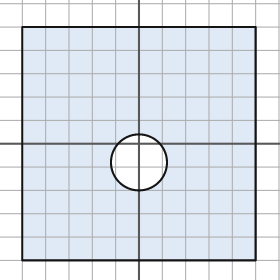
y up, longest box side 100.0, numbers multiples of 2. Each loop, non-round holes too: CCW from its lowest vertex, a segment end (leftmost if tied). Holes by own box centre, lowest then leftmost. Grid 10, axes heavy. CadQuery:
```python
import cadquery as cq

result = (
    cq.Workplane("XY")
    .moveTo(-50.0, -50.0)
    .lineTo(50.0, -50.0)
    .lineTo(50.0, 50.0)
    .lineTo(-50.0, 50.0)
    .close()
    .moveTo(0.0, -8.0)
    .circle(12.0)
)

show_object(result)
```